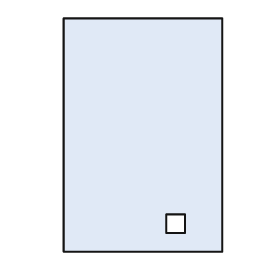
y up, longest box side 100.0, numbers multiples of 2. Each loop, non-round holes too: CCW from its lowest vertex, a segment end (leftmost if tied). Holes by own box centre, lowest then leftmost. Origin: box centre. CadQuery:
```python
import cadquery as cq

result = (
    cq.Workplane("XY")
    .moveTo(-34.0, -50.0)
    .lineTo(34.0, -50.0)
    .lineTo(34.0, 50.0)
    .lineTo(-34.0, 50.0)
    .close()
    .moveTo(10.0, -42.0)
    .lineTo(18.0, -42.0)
    .lineTo(18.0, -34.0)
    .lineTo(10.0, -34.0)
    .close()
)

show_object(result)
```